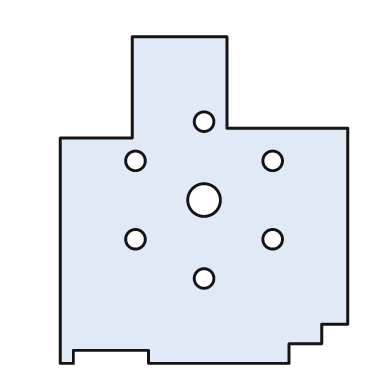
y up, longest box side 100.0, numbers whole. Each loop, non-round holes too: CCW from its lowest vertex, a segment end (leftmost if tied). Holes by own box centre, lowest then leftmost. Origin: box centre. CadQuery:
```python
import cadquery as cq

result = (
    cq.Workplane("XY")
    .moveTo(-44.0, -50.0)
    .lineTo(-40.0, -50.0)
    .lineTo(-40.0, -46.0)
    .lineTo(-17.0, -46.0)
    .lineTo(-17.0, -50.0)
    .lineTo(26.0, -50.0)
    .lineTo(26.0, -44.0)
    .lineTo(36.0, -44.0)
    .lineTo(36.0, -38.0)
    .lineTo(44.0, -38.0)
    .lineTo(44.0, 22.0)
    .lineTo(7.0, 22.0)
    .lineTo(7.0, 50.0)
    .lineTo(-22.0, 50.0)
    .lineTo(-22.0, 19.0)
    .lineTo(-44.0, 19.0)
    .close()
    .moveTo(0.0, -24.0)
    .circle(3.0)
    .moveTo(-21.0, -12.0)
    .circle(3.0)
    .moveTo(21.0, -12.0)
    .circle(3.0)
    .moveTo(0.0, 0.0)
    .circle(5.0)
    .moveTo(-21.0, 12.0)
    .circle(3.0)
    .moveTo(21.0, 12.0)
    .circle(3.0)
    .moveTo(0.0, 24.0)
    .circle(3.0)
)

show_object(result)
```